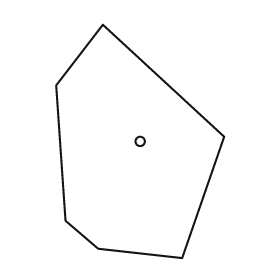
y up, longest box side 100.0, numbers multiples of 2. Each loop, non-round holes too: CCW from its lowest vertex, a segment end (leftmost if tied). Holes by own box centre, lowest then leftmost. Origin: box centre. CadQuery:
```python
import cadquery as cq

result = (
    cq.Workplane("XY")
    .moveTo(18.0, -50.0)
    .lineTo(36.0, 2.0)
    .lineTo(-16.0, 50.0)
    .lineTo(-36.0, 24.0)
    .lineTo(-32.0, -34.0)
    .lineTo(-18.0, -46.0)
    .close()
    .moveTo(0.0, 0.0)
    .circle(2.0)
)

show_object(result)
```